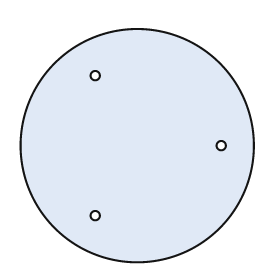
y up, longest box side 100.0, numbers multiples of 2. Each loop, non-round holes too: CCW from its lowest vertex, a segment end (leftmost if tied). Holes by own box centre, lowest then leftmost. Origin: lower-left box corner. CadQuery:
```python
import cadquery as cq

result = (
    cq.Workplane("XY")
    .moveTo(50.0, 50.0)
    .circle(50.0)
    .moveTo(32.0, 20.0)
    .circle(2.0)
    .moveTo(86.0, 50.0)
    .circle(2.0)
    .moveTo(32.0, 80.0)
    .circle(2.0)
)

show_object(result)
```